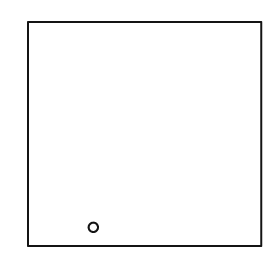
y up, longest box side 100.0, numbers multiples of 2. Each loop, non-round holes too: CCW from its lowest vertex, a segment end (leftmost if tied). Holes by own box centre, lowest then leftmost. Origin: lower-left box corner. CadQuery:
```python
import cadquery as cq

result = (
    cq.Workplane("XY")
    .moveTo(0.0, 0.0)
    .lineTo(100.0, 0.0)
    .lineTo(100.0, 96.0)
    .lineTo(0.0, 96.0)
    .close()
    .moveTo(28.0, 8.0)
    .circle(2.0)
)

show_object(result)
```